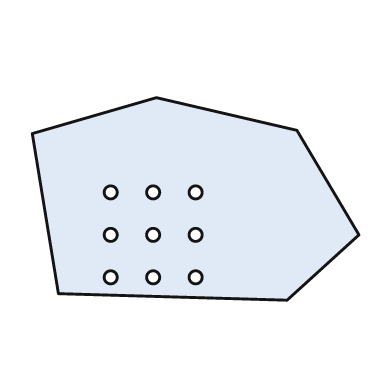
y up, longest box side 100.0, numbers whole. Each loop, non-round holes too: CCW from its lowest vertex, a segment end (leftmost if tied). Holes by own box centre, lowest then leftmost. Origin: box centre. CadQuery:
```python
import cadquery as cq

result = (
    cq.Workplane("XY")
    .moveTo(28.0, -31.0)
    .lineTo(50.0, -11.0)
    .lineTo(31.0, 21.0)
    .lineTo(-12.0, 31.0)
    .lineTo(-50.0, 20.0)
    .lineTo(-42.0, -29.0)
    .close()
    .moveTo(-26.0, -24.0)
    .circle(2.0)
    .moveTo(-13.0, -24.0)
    .circle(2.0)
    .moveTo(0.0, -24.0)
    .circle(2.0)
    .moveTo(-26.0, -11.0)
    .circle(2.0)
    .moveTo(-13.0, -11.0)
    .circle(2.0)
    .moveTo(0.0, -11.0)
    .circle(2.0)
    .moveTo(-26.0, 2.0)
    .circle(2.0)
    .moveTo(-13.0, 2.0)
    .circle(2.0)
    .moveTo(0.0, 2.0)
    .circle(2.0)
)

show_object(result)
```